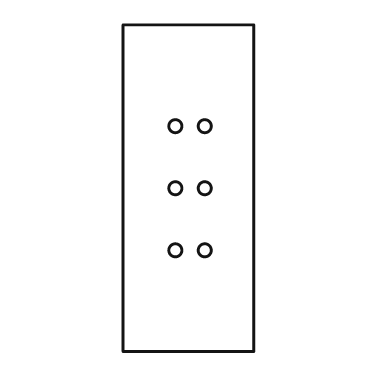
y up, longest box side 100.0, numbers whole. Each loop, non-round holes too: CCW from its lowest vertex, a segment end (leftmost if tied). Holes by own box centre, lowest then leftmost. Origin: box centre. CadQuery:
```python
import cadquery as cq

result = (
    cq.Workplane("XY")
    .moveTo(-20.0, -50.0)
    .lineTo(20.0, -50.0)
    .lineTo(20.0, 50.0)
    .lineTo(-20.0, 50.0)
    .close()
    .moveTo(-4.0, -19.0)
    .circle(2.0)
    .moveTo(5.0, -19.0)
    .circle(2.0)
    .moveTo(-4.0, 0.0)
    .circle(2.0)
    .moveTo(5.0, 0.0)
    .circle(2.0)
    .moveTo(-4.0, 19.0)
    .circle(2.0)
    .moveTo(5.0, 19.0)
    .circle(2.0)
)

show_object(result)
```